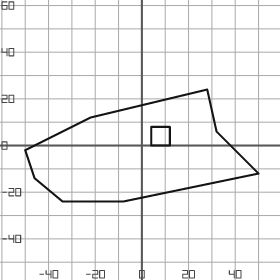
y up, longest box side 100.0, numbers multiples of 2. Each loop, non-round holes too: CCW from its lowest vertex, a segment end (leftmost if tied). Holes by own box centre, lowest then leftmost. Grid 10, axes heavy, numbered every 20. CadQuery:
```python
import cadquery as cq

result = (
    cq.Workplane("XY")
    .moveTo(-34.0, -24.0)
    .lineTo(-8.0, -24.0)
    .lineTo(50.0, -12.0)
    .lineTo(32.0, 6.0)
    .lineTo(28.0, 24.0)
    .lineTo(-22.0, 12.0)
    .lineTo(-50.0, -2.0)
    .lineTo(-46.0, -14.0)
    .close()
    .moveTo(4.0, 0.0)
    .lineTo(12.0, 0.0)
    .lineTo(12.0, 8.0)
    .lineTo(4.0, 8.0)
    .close()
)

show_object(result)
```